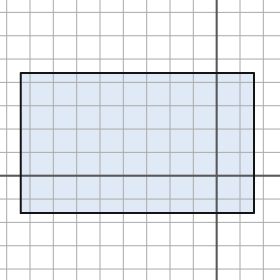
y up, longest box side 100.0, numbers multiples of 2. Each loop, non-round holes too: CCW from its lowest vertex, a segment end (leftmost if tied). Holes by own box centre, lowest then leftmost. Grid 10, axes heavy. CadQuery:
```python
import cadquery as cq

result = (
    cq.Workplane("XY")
    .moveTo(-84.0, -16.0)
    .lineTo(16.0, -16.0)
    .lineTo(16.0, 44.0)
    .lineTo(-84.0, 44.0)
    .close()
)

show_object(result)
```